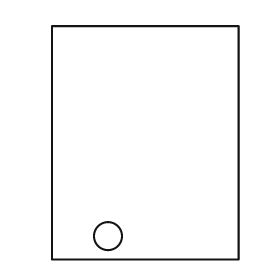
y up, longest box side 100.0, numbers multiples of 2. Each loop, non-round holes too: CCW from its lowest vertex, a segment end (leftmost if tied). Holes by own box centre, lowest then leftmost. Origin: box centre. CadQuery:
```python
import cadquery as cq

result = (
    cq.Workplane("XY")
    .moveTo(-40.0, -50.0)
    .lineTo(40.0, -50.0)
    .lineTo(40.0, 50.0)
    .lineTo(-40.0, 50.0)
    .close()
    .moveTo(-16.0, -40.0)
    .circle(6.0)
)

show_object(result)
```